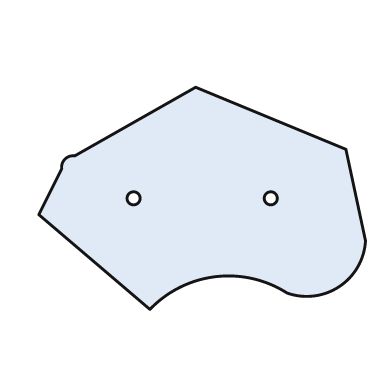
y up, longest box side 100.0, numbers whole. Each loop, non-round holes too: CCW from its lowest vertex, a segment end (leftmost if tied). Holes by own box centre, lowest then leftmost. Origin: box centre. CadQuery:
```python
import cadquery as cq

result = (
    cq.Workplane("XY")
    .moveTo(-16.0, -34.0)
    .threePointArc((4.0, -24.0), (26.0, -29.0))
    .threePointArc((42.0, -27.0), (50.0, -13.0))
    .lineTo(44.0, 15.0)
    .lineTo(-2.0, 34.0)
    .lineTo(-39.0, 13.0)
    .threePointArc((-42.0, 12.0), (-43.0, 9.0))
    .lineTo(-50.0, -5.0)
    .close()
    .moveTo(-21.0, 0.0)
    .circle(2.0)
    .moveTo(21.0, 0.0)
    .circle(2.0)
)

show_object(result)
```